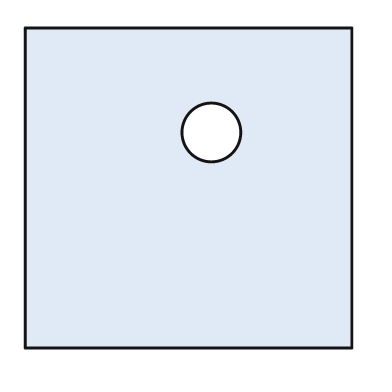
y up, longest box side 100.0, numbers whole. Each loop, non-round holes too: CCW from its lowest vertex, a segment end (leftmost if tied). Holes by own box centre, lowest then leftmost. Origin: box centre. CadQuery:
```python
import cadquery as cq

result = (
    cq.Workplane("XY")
    .moveTo(-50.0, -49.0)
    .lineTo(50.0, -49.0)
    .lineTo(50.0, 49.0)
    .lineTo(-50.0, 49.0)
    .close()
    .moveTo(7.0, 17.0)
    .circle(9.0)
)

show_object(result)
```